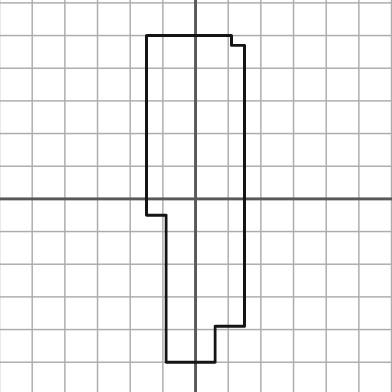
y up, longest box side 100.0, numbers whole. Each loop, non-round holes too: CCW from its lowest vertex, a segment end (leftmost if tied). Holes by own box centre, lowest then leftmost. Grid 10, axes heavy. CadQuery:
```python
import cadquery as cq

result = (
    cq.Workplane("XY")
    .moveTo(-9.0, -50.0)
    .lineTo(6.0, -50.0)
    .lineTo(6.0, -39.0)
    .lineTo(15.0, -39.0)
    .lineTo(15.0, 47.0)
    .lineTo(11.0, 47.0)
    .lineTo(11.0, 50.0)
    .lineTo(-15.0, 50.0)
    .lineTo(-15.0, -5.0)
    .lineTo(-9.0, -5.0)
    .close()
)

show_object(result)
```